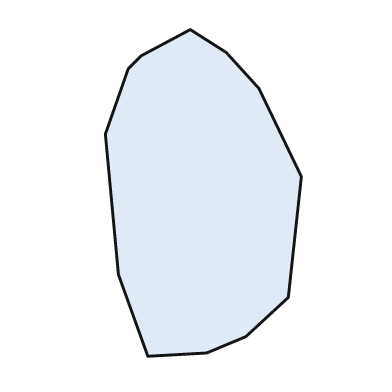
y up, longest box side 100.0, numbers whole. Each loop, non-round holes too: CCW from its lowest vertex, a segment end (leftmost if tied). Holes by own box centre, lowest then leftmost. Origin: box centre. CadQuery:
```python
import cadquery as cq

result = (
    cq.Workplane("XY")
    .moveTo(-17.0, -50.0)
    .lineTo(1.0, -49.0)
    .lineTo(13.0, -44.0)
    .lineTo(26.0, -32.0)
    .lineTo(30.0, 5.0)
    .lineTo(17.0, 32.0)
    .lineTo(7.0, 43.0)
    .lineTo(-4.0, 50.0)
    .lineTo(-19.0, 42.0)
    .lineTo(-23.0, 38.0)
    .lineTo(-30.0, 18.0)
    .lineTo(-26.0, -25.0)
    .close()
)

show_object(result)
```